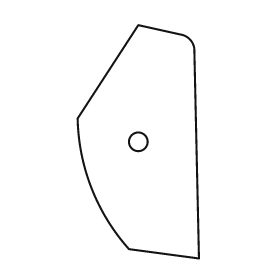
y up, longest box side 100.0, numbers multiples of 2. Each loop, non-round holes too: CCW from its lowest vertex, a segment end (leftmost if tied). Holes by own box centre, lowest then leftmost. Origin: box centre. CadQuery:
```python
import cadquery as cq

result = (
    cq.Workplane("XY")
    .moveTo(26.0, -50.0)
    .lineTo(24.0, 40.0)
    .threePointArc((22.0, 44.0), (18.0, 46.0))
    .lineTo(0.0, 50.0)
    .lineTo(-26.0, 10.0)
    .threePointArc((-20.0, -20.0), (-4.0, -46.0))
    .close()
    .moveTo(0.0, 0.0)
    .circle(4.0)
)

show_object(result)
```